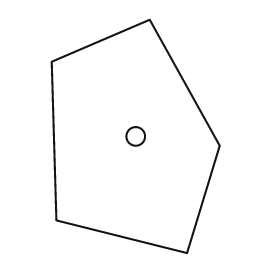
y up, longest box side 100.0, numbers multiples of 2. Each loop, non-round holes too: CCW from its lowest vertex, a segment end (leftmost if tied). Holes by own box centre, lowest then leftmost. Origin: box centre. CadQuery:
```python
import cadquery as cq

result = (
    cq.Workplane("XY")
    .moveTo(22.0, -50.0)
    .lineTo(36.0, -4.0)
    .lineTo(6.0, 50.0)
    .lineTo(-36.0, 32.0)
    .lineTo(-34.0, -36.0)
    .close()
    .moveTo(0.0, 0.0)
    .circle(4.0)
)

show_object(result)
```